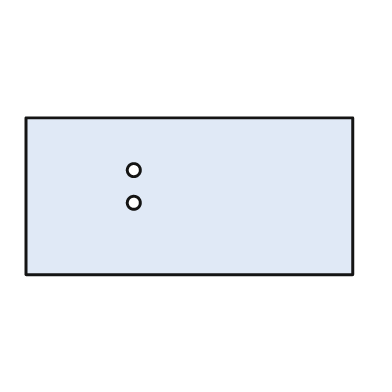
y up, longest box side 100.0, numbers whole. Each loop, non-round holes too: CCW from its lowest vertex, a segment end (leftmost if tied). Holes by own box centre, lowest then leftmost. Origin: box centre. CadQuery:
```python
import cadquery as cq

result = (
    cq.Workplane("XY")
    .moveTo(-50.0, -24.0)
    .lineTo(50.0, -24.0)
    .lineTo(50.0, 24.0)
    .lineTo(-50.0, 24.0)
    .close()
    .moveTo(-17.0, -2.0)
    .circle(2.0)
    .moveTo(-17.0, 8.0)
    .circle(2.0)
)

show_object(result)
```